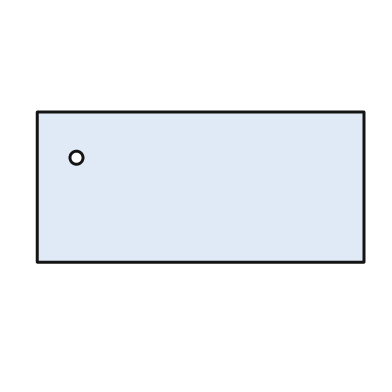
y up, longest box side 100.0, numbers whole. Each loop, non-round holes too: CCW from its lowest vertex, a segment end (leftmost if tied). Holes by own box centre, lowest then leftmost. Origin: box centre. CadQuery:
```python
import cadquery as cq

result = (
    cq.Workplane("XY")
    .moveTo(-50.0, -23.0)
    .lineTo(50.0, -23.0)
    .lineTo(50.0, 23.0)
    .lineTo(-50.0, 23.0)
    .close()
    .moveTo(-38.0, 9.0)
    .circle(2.0)
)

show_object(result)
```